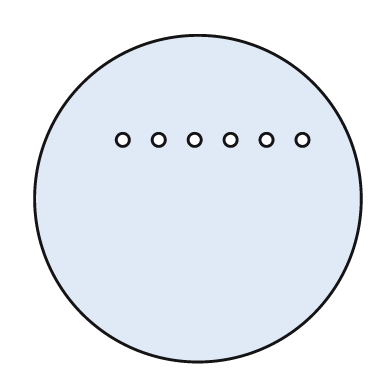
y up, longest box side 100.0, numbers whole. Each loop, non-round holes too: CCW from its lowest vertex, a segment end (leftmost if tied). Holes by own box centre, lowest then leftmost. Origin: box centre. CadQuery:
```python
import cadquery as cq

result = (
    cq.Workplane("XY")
    .moveTo(0.0, 0.0)
    .circle(50.0)
    .moveTo(-23.0, 18.0)
    .circle(2.0)
    .moveTo(-12.0, 18.0)
    .circle(2.0)
    .moveTo(-1.0, 18.0)
    .circle(2.0)
    .moveTo(10.0, 18.0)
    .circle(2.0)
    .moveTo(21.0, 18.0)
    .circle(2.0)
    .moveTo(32.0, 18.0)
    .circle(2.0)
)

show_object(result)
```